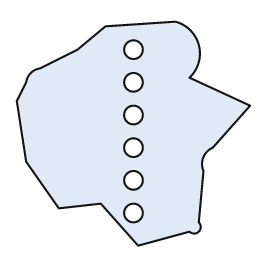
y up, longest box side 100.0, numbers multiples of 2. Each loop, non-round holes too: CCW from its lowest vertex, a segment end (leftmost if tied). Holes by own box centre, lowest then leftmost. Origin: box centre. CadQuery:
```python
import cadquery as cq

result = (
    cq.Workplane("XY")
    .moveTo(2.0, -48.0)
    .lineTo(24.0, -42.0)
    .threePointArc((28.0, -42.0), (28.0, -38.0))
    .lineTo(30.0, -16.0)
    .threePointArc((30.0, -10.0), (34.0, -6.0))
    .lineTo(50.0, 12.0)
    .lineTo(24.0, 24.0)
    .threePointArc((28.0, 38.0), (18.0, 48.0))
    .lineTo(-12.0, 46.0)
    .lineTo(-24.0, 36.0)
    .lineTo(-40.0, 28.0)
    .threePointArc((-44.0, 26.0), (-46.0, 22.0))
    .lineTo(-50.0, 14.0)
    .lineTo(-46.0, -12.0)
    .lineTo(-32.0, -32.0)
    .lineTo(-14.0, -30.0)
    .close()
    .moveTo(0.0, -34.0)
    .circle(4.0)
    .moveTo(0.0, -20.0)
    .circle(4.0)
    .moveTo(0.0, -6.0)
    .circle(4.0)
    .moveTo(0.0, 8.0)
    .circle(4.0)
    .moveTo(0.0, 22.0)
    .circle(4.0)
    .moveTo(0.0, 36.0)
    .circle(4.0)
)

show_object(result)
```